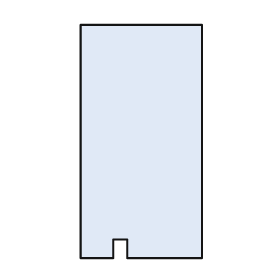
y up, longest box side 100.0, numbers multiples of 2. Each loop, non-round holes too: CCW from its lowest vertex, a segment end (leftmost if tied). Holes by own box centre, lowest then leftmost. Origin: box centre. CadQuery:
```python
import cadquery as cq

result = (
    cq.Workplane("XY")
    .moveTo(-26.0, -50.0)
    .lineTo(-12.0, -50.0)
    .lineTo(-12.0, -42.0)
    .lineTo(-6.0, -42.0)
    .lineTo(-6.0, -50.0)
    .lineTo(26.0, -50.0)
    .lineTo(26.0, 50.0)
    .lineTo(-26.0, 50.0)
    .close()
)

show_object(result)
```